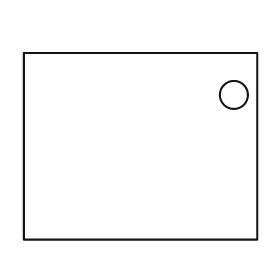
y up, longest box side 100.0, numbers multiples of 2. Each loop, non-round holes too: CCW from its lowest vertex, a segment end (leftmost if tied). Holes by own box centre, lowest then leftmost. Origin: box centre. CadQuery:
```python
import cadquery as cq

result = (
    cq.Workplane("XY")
    .moveTo(-50.0, -40.0)
    .lineTo(50.0, -40.0)
    .lineTo(50.0, 40.0)
    .lineTo(-50.0, 40.0)
    .close()
    .moveTo(40.0, 22.0)
    .circle(6.0)
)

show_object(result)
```